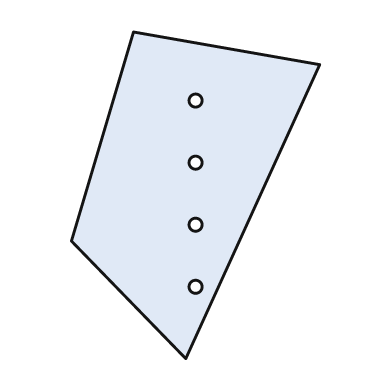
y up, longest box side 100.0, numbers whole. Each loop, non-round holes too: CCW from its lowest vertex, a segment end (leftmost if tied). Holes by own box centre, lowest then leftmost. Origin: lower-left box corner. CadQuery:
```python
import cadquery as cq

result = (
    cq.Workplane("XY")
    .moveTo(35.0, 0.0)
    .lineTo(76.0, 90.0)
    .lineTo(19.0, 100.0)
    .lineTo(0.0, 36.0)
    .close()
    .moveTo(38.0, 22.0)
    .circle(2.0)
    .moveTo(38.0, 41.0)
    .circle(2.0)
    .moveTo(38.0, 60.0)
    .circle(2.0)
    .moveTo(38.0, 79.0)
    .circle(2.0)
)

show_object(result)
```